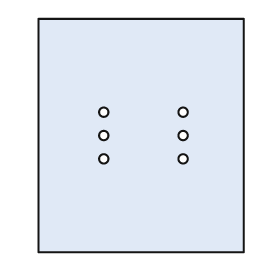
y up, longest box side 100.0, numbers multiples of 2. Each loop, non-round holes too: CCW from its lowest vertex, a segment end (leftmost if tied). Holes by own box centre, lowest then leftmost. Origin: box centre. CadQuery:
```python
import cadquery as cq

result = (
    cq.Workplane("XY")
    .moveTo(-44.0, -50.0)
    .lineTo(44.0, -50.0)
    .lineTo(44.0, 50.0)
    .lineTo(-44.0, 50.0)
    .close()
    .moveTo(-16.0, -10.0)
    .circle(2.0)
    .moveTo(18.0, -10.0)
    .circle(2.0)
    .moveTo(-16.0, 0.0)
    .circle(2.0)
    .moveTo(18.0, 0.0)
    .circle(2.0)
    .moveTo(-16.0, 10.0)
    .circle(2.0)
    .moveTo(18.0, 10.0)
    .circle(2.0)
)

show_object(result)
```